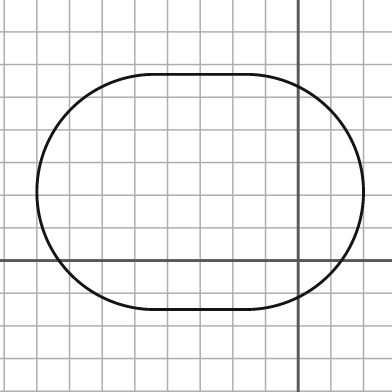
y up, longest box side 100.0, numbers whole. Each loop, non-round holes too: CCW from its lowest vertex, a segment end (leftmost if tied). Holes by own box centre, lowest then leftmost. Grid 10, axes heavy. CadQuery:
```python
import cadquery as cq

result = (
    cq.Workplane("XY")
    .moveTo(-44.0, -15.0)
    .lineTo(-16.0, -15.0)
    .threePointArc((20.0, 21.0), (-16.0, 57.0))
    .lineTo(-44.0, 57.0)
    .threePointArc((-80.0, 21.0), (-44.0, -15.0))
    .close()
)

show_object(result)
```